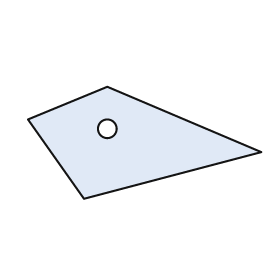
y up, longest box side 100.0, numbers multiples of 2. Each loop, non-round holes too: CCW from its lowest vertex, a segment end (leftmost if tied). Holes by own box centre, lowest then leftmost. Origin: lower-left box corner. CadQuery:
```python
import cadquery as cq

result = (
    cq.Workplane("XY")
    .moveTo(24.0, 0.0)
    .lineTo(100.0, 20.0)
    .lineTo(34.0, 48.0)
    .lineTo(0.0, 34.0)
    .close()
    .moveTo(34.0, 30.0)
    .circle(4.0)
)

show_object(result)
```